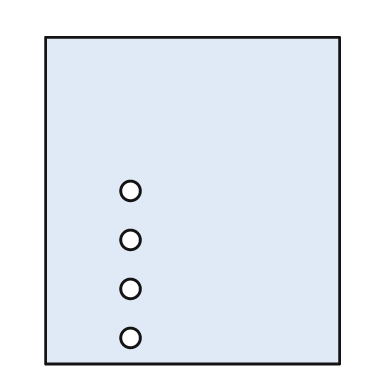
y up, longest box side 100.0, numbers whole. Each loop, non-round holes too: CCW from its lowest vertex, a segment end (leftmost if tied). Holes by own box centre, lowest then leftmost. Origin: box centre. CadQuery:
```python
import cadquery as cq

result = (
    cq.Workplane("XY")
    .moveTo(-45.0, -50.0)
    .lineTo(45.0, -50.0)
    .lineTo(45.0, 50.0)
    .lineTo(-45.0, 50.0)
    .close()
    .moveTo(-19.0, -42.0)
    .circle(3.0)
    .moveTo(-19.0, -27.0)
    .circle(3.0)
    .moveTo(-19.0, -12.0)
    .circle(3.0)
    .moveTo(-19.0, 3.0)
    .circle(3.0)
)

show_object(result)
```